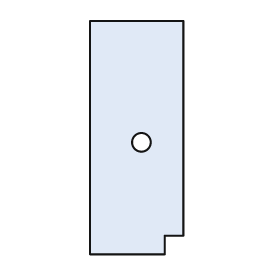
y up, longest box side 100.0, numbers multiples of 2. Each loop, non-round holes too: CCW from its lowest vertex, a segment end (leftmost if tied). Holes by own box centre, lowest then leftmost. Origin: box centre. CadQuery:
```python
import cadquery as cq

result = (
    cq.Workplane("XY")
    .moveTo(-20.0, -50.0)
    .lineTo(12.0, -50.0)
    .lineTo(12.0, -42.0)
    .lineTo(20.0, -42.0)
    .lineTo(20.0, 50.0)
    .lineTo(-20.0, 50.0)
    .close()
    .moveTo(2.0, -2.0)
    .circle(4.0)
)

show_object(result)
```